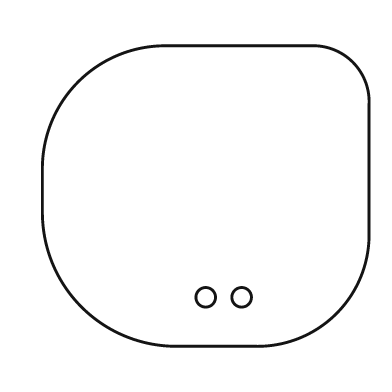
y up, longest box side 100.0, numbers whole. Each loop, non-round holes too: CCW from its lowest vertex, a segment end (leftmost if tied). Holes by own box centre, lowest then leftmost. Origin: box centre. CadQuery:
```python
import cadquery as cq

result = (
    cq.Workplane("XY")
    .moveTo(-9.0, -46.0)
    .lineTo(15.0, -46.0)
    .threePointArc((40.0, -36.0), (50.0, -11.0))
    .lineTo(50.0, 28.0)
    .threePointArc((45.0, 41.0), (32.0, 46.0))
    .lineTo(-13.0, 46.0)
    .threePointArc((-39.0, 35.0), (-50.0, 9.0))
    .lineTo(-50.0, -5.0)
    .threePointArc((-38.0, -34.0), (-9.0, -46.0))
    .close()
    .moveTo(0.0, -31.0)
    .circle(3.0)
    .moveTo(11.0, -31.0)
    .circle(3.0)
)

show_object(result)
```